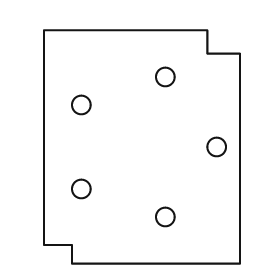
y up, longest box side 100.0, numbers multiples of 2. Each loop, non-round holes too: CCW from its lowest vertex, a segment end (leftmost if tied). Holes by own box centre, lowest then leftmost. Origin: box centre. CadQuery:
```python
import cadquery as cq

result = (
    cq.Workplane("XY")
    .moveTo(-30.0, -50.0)
    .lineTo(42.0, -50.0)
    .lineTo(42.0, 40.0)
    .lineTo(28.0, 40.0)
    .lineTo(28.0, 50.0)
    .lineTo(-42.0, 50.0)
    .lineTo(-42.0, -42.0)
    .lineTo(-30.0, -42.0)
    .close()
    .moveTo(10.0, -30.0)
    .circle(4.0)
    .moveTo(-26.0, -18.0)
    .circle(4.0)
    .moveTo(32.0, 0.0)
    .circle(4.0)
    .moveTo(-26.0, 18.0)
    .circle(4.0)
    .moveTo(10.0, 30.0)
    .circle(4.0)
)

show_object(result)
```